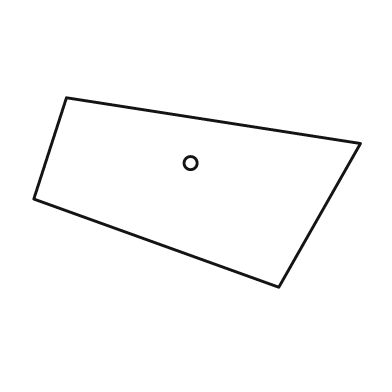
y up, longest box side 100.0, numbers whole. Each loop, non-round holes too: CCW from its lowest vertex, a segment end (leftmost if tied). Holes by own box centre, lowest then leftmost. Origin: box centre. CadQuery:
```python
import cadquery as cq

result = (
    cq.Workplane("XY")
    .moveTo(25.0, -29.0)
    .lineTo(50.0, 15.0)
    .lineTo(-40.0, 29.0)
    .lineTo(-50.0, -2.0)
    .close()
    .moveTo(-2.0, 9.0)
    .circle(2.0)
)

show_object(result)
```